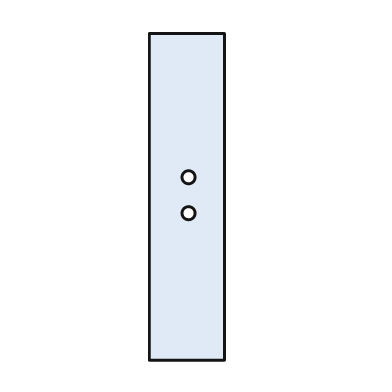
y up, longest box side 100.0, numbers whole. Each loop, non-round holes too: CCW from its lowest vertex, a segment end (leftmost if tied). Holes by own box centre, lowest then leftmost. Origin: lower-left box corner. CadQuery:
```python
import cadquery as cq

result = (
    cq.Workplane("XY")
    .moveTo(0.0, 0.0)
    .lineTo(23.0, 0.0)
    .lineTo(23.0, 100.0)
    .lineTo(0.0, 100.0)
    .close()
    .moveTo(12.0, 45.0)
    .circle(2.0)
    .moveTo(12.0, 56.0)
    .circle(2.0)
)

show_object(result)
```